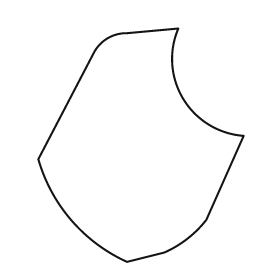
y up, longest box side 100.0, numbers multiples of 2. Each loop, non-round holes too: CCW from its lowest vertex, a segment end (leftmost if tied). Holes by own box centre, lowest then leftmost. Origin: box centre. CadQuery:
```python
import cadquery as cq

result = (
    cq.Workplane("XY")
    .moveTo(-6.0, -50.0)
    .lineTo(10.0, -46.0)
    .threePointArc((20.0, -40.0), (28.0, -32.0))
    .lineTo(44.0, 4.0)
    .threePointArc((18.0, 20.0), (16.0, 50.0))
    .lineTo(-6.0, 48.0)
    .threePointArc((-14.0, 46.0), (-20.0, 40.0))
    .lineTo(-44.0, -6.0)
    .threePointArc((-30.0, -32.0), (-6.0, -50.0))
    .close()
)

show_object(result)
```